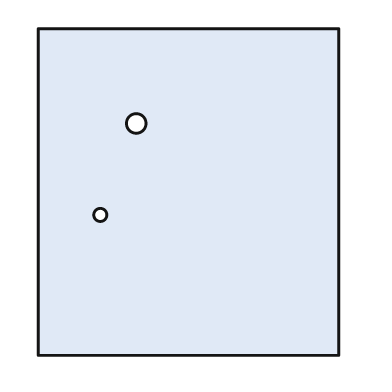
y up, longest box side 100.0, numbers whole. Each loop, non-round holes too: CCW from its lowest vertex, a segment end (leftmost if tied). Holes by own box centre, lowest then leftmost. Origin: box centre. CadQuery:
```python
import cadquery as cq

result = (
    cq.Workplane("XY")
    .moveTo(-46.0, -50.0)
    .lineTo(46.0, -50.0)
    .lineTo(46.0, 50.0)
    .lineTo(-46.0, 50.0)
    .close()
    .moveTo(-27.0, -7.0)
    .circle(2.0)
    .moveTo(-16.0, 21.0)
    .circle(3.0)
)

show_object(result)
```